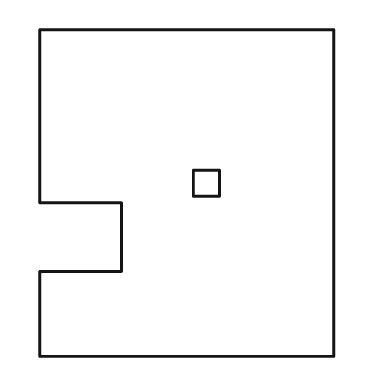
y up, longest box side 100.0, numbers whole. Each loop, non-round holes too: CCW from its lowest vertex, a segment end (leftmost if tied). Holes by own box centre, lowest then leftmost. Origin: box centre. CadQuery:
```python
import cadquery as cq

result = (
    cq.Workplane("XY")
    .moveTo(-45.0, -50.0)
    .lineTo(45.0, -50.0)
    .lineTo(45.0, 50.0)
    .lineTo(-45.0, 50.0)
    .lineTo(-45.0, -3.0)
    .lineTo(-20.0, -3.0)
    .lineTo(-20.0, -24.0)
    .lineTo(-45.0, -24.0)
    .close()
    .moveTo(2.0, -1.0)
    .lineTo(10.0, -1.0)
    .lineTo(10.0, 7.0)
    .lineTo(2.0, 7.0)
    .close()
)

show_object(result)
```